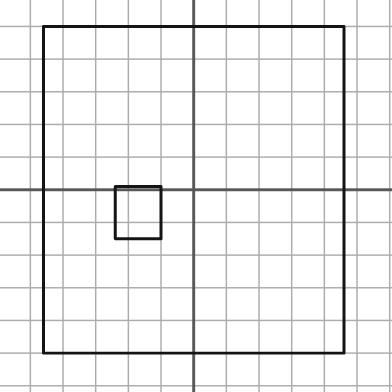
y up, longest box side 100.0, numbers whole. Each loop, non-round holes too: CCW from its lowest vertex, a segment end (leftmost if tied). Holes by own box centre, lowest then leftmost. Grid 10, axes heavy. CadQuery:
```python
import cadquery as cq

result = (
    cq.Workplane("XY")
    .moveTo(-46.0, -50.0)
    .lineTo(46.0, -50.0)
    .lineTo(46.0, 50.0)
    .lineTo(-46.0, 50.0)
    .close()
    .moveTo(-24.0, -15.0)
    .lineTo(-10.0, -15.0)
    .lineTo(-10.0, 1.0)
    .lineTo(-24.0, 1.0)
    .close()
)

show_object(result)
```